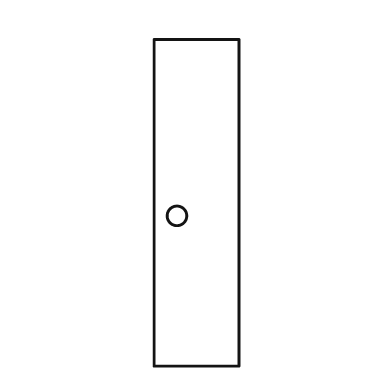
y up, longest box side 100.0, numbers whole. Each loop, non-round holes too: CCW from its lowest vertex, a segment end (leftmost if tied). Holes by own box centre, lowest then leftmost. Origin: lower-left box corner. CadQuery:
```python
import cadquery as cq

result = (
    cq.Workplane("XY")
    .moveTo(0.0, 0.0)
    .lineTo(26.0, 0.0)
    .lineTo(26.0, 100.0)
    .lineTo(0.0, 100.0)
    .close()
    .moveTo(7.0, 46.0)
    .circle(3.0)
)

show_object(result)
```